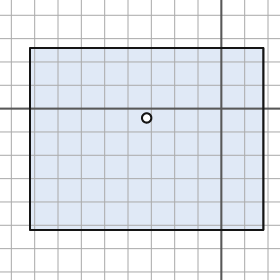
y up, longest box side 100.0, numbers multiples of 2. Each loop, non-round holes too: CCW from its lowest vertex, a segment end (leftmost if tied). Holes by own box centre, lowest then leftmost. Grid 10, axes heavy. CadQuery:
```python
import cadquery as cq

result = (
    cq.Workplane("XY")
    .moveTo(-82.0, -52.0)
    .lineTo(18.0, -52.0)
    .lineTo(18.0, 26.0)
    .lineTo(-82.0, 26.0)
    .close()
    .moveTo(-32.0, -4.0)
    .circle(2.0)
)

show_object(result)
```